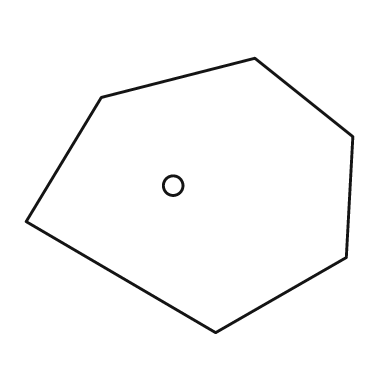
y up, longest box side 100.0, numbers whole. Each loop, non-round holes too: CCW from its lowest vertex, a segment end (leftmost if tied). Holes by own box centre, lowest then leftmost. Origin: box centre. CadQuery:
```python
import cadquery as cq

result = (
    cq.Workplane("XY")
    .moveTo(8.0, -42.0)
    .lineTo(48.0, -19.0)
    .lineTo(50.0, 18.0)
    .lineTo(20.0, 42.0)
    .lineTo(-27.0, 30.0)
    .lineTo(-50.0, -8.0)
    .close()
    .moveTo(-5.0, 3.0)
    .circle(3.0)
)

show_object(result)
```